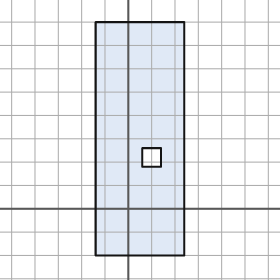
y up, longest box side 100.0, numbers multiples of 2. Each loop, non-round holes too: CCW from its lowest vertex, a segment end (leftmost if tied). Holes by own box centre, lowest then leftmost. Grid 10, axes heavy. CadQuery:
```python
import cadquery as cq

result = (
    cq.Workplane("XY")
    .moveTo(-14.0, -20.0)
    .lineTo(24.0, -20.0)
    .lineTo(24.0, 80.0)
    .lineTo(-14.0, 80.0)
    .close()
    .moveTo(6.0, 18.0)
    .lineTo(14.0, 18.0)
    .lineTo(14.0, 26.0)
    .lineTo(6.0, 26.0)
    .close()
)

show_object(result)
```